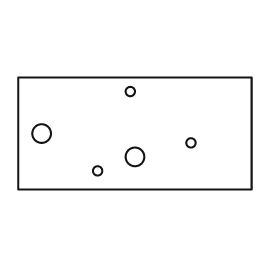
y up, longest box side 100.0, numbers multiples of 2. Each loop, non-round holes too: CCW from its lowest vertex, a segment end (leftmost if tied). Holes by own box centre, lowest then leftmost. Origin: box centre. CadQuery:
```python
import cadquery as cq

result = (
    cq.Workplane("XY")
    .moveTo(-50.0, -24.0)
    .lineTo(50.0, -24.0)
    .lineTo(50.0, 24.0)
    .lineTo(-50.0, 24.0)
    .close()
    .moveTo(-16.0, -16.0)
    .circle(2.0)
    .moveTo(0.0, -10.0)
    .circle(4.0)
    .moveTo(24.0, -4.0)
    .circle(2.0)
    .moveTo(-40.0, 0.0)
    .circle(4.0)
    .moveTo(-2.0, 18.0)
    .circle(2.0)
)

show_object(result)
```